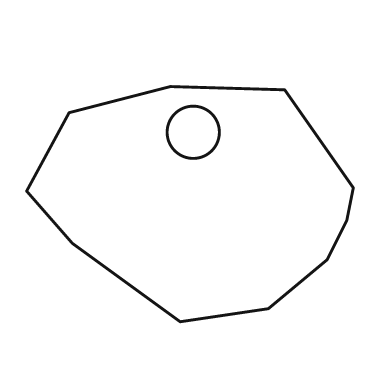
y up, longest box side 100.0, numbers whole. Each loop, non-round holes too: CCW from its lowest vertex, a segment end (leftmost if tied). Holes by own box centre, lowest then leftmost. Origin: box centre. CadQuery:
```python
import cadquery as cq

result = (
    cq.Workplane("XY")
    .moveTo(-3.0, -36.0)
    .lineTo(24.0, -32.0)
    .lineTo(42.0, -17.0)
    .lineTo(48.0, -5.0)
    .lineTo(50.0, 5.0)
    .lineTo(29.0, 35.0)
    .lineTo(-6.0, 36.0)
    .lineTo(-37.0, 28.0)
    .lineTo(-50.0, 4.0)
    .lineTo(-36.0, -12.0)
    .close()
    .moveTo(1.0, 22.0)
    .circle(8.0)
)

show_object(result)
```